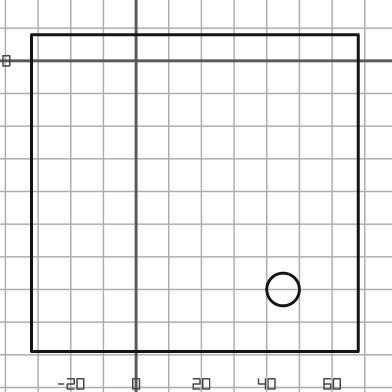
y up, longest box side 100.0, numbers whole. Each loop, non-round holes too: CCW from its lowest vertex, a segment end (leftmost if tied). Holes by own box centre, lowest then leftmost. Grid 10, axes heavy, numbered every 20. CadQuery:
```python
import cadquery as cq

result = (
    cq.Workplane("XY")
    .moveTo(-32.0, -89.0)
    .lineTo(68.0, -89.0)
    .lineTo(68.0, 8.0)
    .lineTo(-32.0, 8.0)
    .close()
    .moveTo(45.0, -70.0)
    .circle(5.0)
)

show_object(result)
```